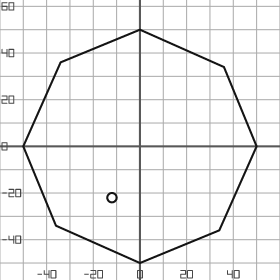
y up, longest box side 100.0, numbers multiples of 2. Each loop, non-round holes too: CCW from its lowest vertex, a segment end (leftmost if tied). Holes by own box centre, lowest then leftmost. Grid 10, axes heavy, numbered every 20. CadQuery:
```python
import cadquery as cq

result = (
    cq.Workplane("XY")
    .moveTo(0.0, -50.0)
    .lineTo(34.0, -36.0)
    .lineTo(50.0, 0.0)
    .lineTo(36.0, 34.0)
    .lineTo(0.0, 50.0)
    .lineTo(-34.0, 36.0)
    .lineTo(-50.0, 0.0)
    .lineTo(-36.0, -34.0)
    .close()
    .moveTo(-12.0, -22.0)
    .circle(2.0)
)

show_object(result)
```